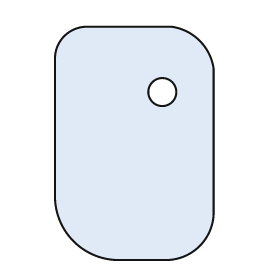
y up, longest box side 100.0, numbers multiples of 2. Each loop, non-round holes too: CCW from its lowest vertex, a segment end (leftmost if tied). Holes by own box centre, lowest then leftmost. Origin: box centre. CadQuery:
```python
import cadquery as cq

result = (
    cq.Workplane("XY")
    .moveTo(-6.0, -50.0)
    .lineTo(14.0, -50.0)
    .threePointArc((28.0, -44.0), (34.0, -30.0))
    .lineTo(34.0, 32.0)
    .threePointArc((28.0, 44.0), (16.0, 50.0))
    .lineTo(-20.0, 50.0)
    .threePointArc((-30.0, 46.0), (-34.0, 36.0))
    .lineTo(-34.0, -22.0)
    .threePointArc((-26.0, -42.0), (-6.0, -50.0))
    .close()
    .moveTo(12.0, 22.0)
    .circle(6.0)
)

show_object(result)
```